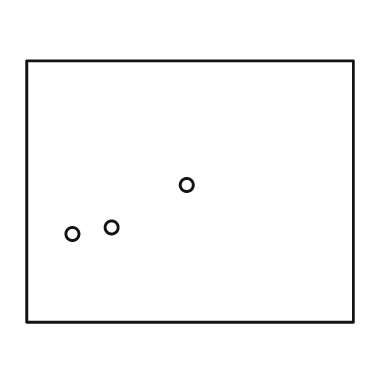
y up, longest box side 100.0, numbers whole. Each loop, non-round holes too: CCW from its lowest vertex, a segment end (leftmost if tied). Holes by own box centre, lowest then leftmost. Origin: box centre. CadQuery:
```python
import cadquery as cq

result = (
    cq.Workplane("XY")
    .moveTo(-50.0, -40.0)
    .lineTo(50.0, -40.0)
    .lineTo(50.0, 40.0)
    .lineTo(-50.0, 40.0)
    .close()
    .moveTo(-36.0, -13.0)
    .circle(2.0)
    .moveTo(-24.0, -11.0)
    .circle(2.0)
    .moveTo(-1.0, 2.0)
    .circle(2.0)
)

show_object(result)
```